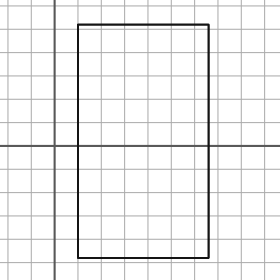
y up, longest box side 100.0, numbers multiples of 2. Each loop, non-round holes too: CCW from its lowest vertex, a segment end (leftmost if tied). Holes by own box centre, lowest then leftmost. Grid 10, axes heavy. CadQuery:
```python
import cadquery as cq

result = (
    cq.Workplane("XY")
    .moveTo(10.0, -48.0)
    .lineTo(66.0, -48.0)
    .lineTo(66.0, 52.0)
    .lineTo(10.0, 52.0)
    .close()
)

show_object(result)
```